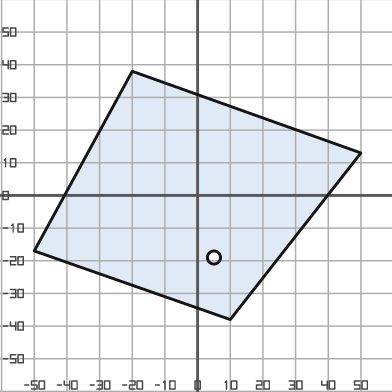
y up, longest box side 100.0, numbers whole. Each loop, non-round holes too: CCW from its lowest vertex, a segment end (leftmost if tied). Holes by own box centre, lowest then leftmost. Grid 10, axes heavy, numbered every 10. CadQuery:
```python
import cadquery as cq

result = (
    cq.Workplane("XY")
    .moveTo(10.0, -38.0)
    .lineTo(50.0, 13.0)
    .lineTo(-20.0, 38.0)
    .lineTo(-50.0, -17.0)
    .close()
    .moveTo(5.0, -19.0)
    .circle(2.0)
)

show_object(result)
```